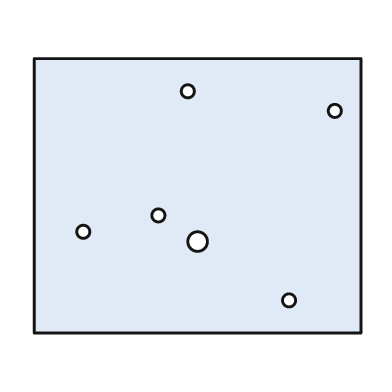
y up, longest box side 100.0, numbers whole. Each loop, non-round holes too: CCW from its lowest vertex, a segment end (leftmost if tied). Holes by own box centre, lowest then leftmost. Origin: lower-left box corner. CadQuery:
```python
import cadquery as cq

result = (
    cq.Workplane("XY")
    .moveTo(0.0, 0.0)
    .lineTo(100.0, 0.0)
    .lineTo(100.0, 84.0)
    .lineTo(0.0, 84.0)
    .close()
    .moveTo(78.0, 10.0)
    .circle(2.0)
    .moveTo(50.0, 28.0)
    .circle(3.0)
    .moveTo(15.0, 31.0)
    .circle(2.0)
    .moveTo(38.0, 36.0)
    .circle(2.0)
    .moveTo(92.0, 68.0)
    .circle(2.0)
    .moveTo(47.0, 74.0)
    .circle(2.0)
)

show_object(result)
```